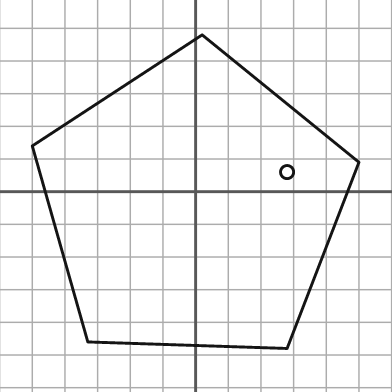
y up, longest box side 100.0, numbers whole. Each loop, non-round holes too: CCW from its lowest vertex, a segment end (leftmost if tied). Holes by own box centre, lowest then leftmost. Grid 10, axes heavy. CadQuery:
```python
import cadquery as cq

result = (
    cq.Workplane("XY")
    .moveTo(28.0, -48.0)
    .lineTo(50.0, 9.0)
    .lineTo(2.0, 48.0)
    .lineTo(-50.0, 14.0)
    .lineTo(-33.0, -46.0)
    .close()
    .moveTo(28.0, 6.0)
    .circle(2.0)
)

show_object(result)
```